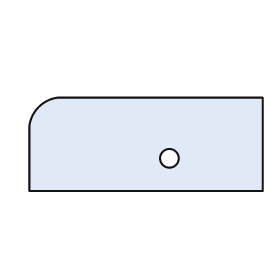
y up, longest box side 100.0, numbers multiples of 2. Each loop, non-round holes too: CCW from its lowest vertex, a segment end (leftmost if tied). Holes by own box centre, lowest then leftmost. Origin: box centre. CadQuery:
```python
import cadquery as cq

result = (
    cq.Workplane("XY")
    .moveTo(-50.0, -20.0)
    .lineTo(50.0, -20.0)
    .lineTo(50.0, 20.0)
    .lineTo(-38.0, 20.0)
    .threePointArc((-46.0, 16.0), (-50.0, 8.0))
    .close()
    .moveTo(10.0, -6.0)
    .circle(4.0)
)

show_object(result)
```